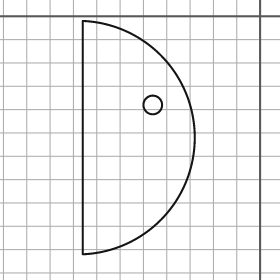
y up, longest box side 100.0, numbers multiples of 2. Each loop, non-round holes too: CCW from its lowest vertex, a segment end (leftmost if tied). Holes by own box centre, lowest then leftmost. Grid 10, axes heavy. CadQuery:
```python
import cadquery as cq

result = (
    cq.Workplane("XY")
    .moveTo(-76.0, -102.0)
    .threePointArc((-28.0, -52.0), (-76.0, -2.0))
    .close()
    .moveTo(-46.0, -38.0)
    .circle(4.0)
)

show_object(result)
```